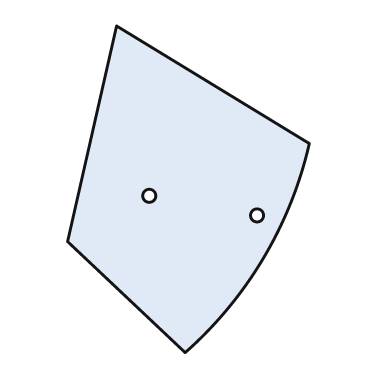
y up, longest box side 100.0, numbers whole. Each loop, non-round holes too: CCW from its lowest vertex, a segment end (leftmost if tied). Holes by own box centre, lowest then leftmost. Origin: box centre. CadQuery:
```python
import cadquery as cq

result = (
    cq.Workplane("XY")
    .moveTo(-1.0, -50.0)
    .threePointArc((23.0, -21.0), (37.0, 14.0))
    .lineTo(-22.0, 50.0)
    .lineTo(-37.0, -16.0)
    .close()
    .moveTo(21.0, -8.0)
    .circle(2.0)
    .moveTo(-12.0, -2.0)
    .circle(2.0)
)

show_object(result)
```